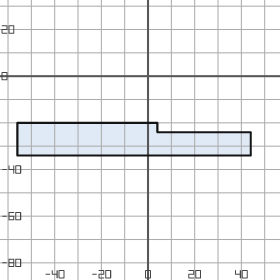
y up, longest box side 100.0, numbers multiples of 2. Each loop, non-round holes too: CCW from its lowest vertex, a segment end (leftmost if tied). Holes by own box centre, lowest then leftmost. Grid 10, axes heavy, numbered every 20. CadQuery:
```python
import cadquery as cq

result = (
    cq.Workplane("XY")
    .moveTo(-56.0, -34.0)
    .lineTo(44.0, -34.0)
    .lineTo(44.0, -24.0)
    .lineTo(4.0, -24.0)
    .lineTo(4.0, -20.0)
    .lineTo(-56.0, -20.0)
    .close()
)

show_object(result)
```